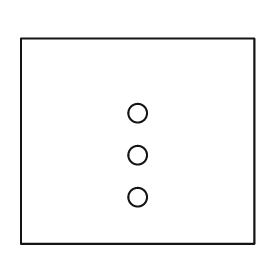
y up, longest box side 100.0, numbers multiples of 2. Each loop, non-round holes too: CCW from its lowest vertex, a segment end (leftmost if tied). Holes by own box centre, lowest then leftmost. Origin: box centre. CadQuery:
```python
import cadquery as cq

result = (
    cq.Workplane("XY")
    .moveTo(-50.0, -44.0)
    .lineTo(50.0, -44.0)
    .lineTo(50.0, 44.0)
    .lineTo(-50.0, 44.0)
    .close()
    .moveTo(0.0, -24.0)
    .circle(4.0)
    .moveTo(0.0, -6.0)
    .circle(4.0)
    .moveTo(0.0, 12.0)
    .circle(4.0)
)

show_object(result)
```